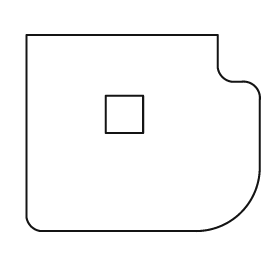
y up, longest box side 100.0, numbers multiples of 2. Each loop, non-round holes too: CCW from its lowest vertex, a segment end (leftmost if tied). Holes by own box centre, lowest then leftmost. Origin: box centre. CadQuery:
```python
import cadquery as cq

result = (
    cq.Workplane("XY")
    .moveTo(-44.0, -42.0)
    .lineTo(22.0, -42.0)
    .threePointArc((42.0, -34.0), (50.0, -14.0))
    .lineTo(50.0, 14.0)
    .threePointArc((48.0, 20.0), (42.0, 22.0))
    .lineTo(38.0, 22.0)
    .threePointArc((34.0, 24.0), (32.0, 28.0))
    .lineTo(32.0, 42.0)
    .lineTo(-50.0, 42.0)
    .lineTo(-50.0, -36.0)
    .threePointArc((-48.0, -40.0), (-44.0, -42.0))
    .close()
    .moveTo(-16.0, 0.0)
    .lineTo(0.0, 0.0)
    .lineTo(0.0, 16.0)
    .lineTo(-16.0, 16.0)
    .close()
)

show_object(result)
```